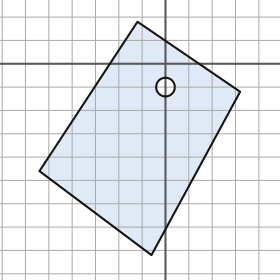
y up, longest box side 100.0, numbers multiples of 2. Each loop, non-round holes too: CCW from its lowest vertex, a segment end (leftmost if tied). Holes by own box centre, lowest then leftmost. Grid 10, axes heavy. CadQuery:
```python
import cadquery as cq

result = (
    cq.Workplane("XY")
    .moveTo(-6.0, -82.0)
    .lineTo(32.0, -12.0)
    .lineTo(-12.0, 18.0)
    .lineTo(-54.0, -46.0)
    .close()
    .moveTo(0.0, -10.0)
    .circle(4.0)
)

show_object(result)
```